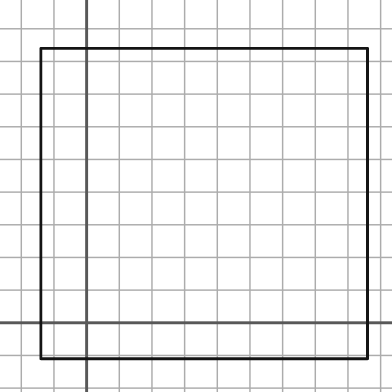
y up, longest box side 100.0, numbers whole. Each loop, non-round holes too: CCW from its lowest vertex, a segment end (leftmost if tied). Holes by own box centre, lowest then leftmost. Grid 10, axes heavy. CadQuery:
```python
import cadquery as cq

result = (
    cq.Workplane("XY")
    .moveTo(-14.0, -11.0)
    .lineTo(86.0, -11.0)
    .lineTo(86.0, 84.0)
    .lineTo(-14.0, 84.0)
    .close()
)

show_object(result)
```